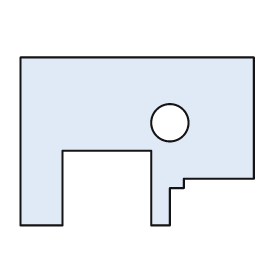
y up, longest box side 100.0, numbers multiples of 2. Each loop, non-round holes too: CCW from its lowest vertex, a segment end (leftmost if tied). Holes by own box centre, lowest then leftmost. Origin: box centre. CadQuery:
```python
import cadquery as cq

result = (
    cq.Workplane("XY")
    .moveTo(-50.0, -36.0)
    .lineTo(-32.0, -36.0)
    .lineTo(-32.0, -4.0)
    .lineTo(6.0, -4.0)
    .lineTo(6.0, -36.0)
    .lineTo(14.0, -36.0)
    .lineTo(14.0, -20.0)
    .lineTo(20.0, -20.0)
    .lineTo(20.0, -16.0)
    .lineTo(50.0, -16.0)
    .lineTo(50.0, 36.0)
    .lineTo(-50.0, 36.0)
    .close()
    .moveTo(14.0, 8.0)
    .circle(8.0)
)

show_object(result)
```